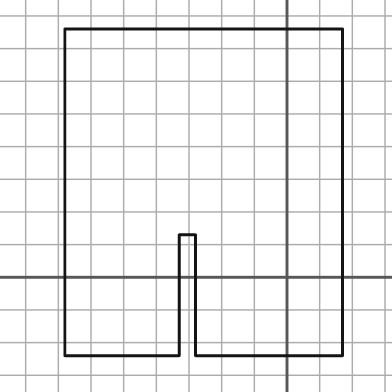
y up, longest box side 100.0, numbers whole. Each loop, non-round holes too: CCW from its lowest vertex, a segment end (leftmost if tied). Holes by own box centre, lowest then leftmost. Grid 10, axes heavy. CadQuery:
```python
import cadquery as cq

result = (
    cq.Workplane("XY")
    .moveTo(-68.0, -24.0)
    .lineTo(-33.0, -24.0)
    .lineTo(-33.0, 13.0)
    .lineTo(-28.0, 13.0)
    .lineTo(-28.0, -24.0)
    .lineTo(17.0, -24.0)
    .lineTo(17.0, 76.0)
    .lineTo(-68.0, 76.0)
    .close()
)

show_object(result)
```